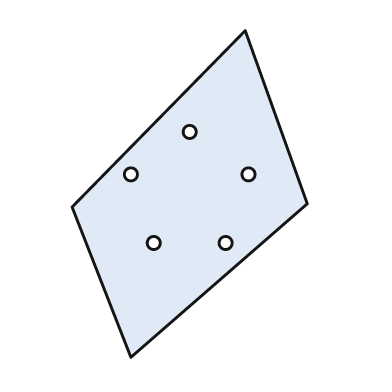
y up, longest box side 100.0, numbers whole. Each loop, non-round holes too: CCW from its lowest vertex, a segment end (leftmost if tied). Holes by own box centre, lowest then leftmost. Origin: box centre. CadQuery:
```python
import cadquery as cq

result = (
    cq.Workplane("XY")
    .moveTo(-18.0, -50.0)
    .lineTo(36.0, -3.0)
    .lineTo(17.0, 50.0)
    .lineTo(-36.0, -4.0)
    .close()
    .moveTo(-11.0, -15.0)
    .circle(2.0)
    .moveTo(11.0, -15.0)
    .circle(2.0)
    .moveTo(-18.0, 6.0)
    .circle(2.0)
    .moveTo(18.0, 6.0)
    .circle(2.0)
    .moveTo(0.0, 19.0)
    .circle(2.0)
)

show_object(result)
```